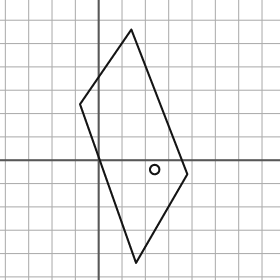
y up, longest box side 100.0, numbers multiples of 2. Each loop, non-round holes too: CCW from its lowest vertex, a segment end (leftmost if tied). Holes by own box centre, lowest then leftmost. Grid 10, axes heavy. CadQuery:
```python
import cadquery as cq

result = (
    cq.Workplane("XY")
    .moveTo(16.0, -44.0)
    .lineTo(38.0, -6.0)
    .lineTo(14.0, 56.0)
    .lineTo(-8.0, 24.0)
    .close()
    .moveTo(24.0, -4.0)
    .circle(2.0)
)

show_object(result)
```